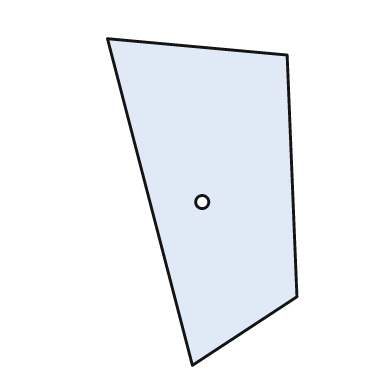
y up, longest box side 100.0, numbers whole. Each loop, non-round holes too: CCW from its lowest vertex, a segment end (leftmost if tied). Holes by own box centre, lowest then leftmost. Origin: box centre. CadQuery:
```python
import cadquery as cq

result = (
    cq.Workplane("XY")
    .moveTo(-3.0, -50.0)
    .lineTo(29.0, -29.0)
    .lineTo(26.0, 45.0)
    .lineTo(-29.0, 50.0)
    .close()
    .moveTo(0.0, 0.0)
    .circle(2.0)
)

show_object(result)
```